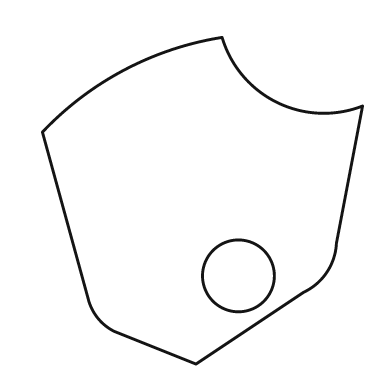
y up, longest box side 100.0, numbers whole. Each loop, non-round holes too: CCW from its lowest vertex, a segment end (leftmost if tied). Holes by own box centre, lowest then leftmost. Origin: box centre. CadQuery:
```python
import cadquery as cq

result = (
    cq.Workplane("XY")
    .moveTo(-2.0, -50.0)
    .lineTo(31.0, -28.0)
    .threePointArc((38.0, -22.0), (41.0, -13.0))
    .lineTo(49.0, 29.0)
    .threePointArc((23.0, 30.0), (6.0, 50.0))
    .threePointArc((-24.0, 40.0), (-49.0, 21.0))
    .lineTo(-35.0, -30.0)
    .threePointArc((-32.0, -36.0), (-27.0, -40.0))
    .close()
    .moveTo(11.0, -23.0)
    .circle(11.0)
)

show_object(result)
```